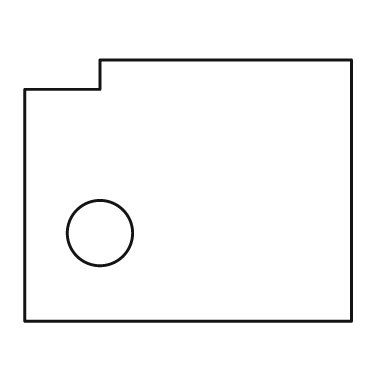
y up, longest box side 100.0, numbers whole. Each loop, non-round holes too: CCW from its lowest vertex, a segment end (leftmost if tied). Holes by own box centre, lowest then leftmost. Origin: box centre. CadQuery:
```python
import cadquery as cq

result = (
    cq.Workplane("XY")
    .moveTo(-50.0, -40.0)
    .lineTo(50.0, -40.0)
    .lineTo(50.0, 40.0)
    .lineTo(-27.0, 40.0)
    .lineTo(-27.0, 31.0)
    .lineTo(-50.0, 31.0)
    .close()
    .moveTo(-27.0, -13.0)
    .circle(10.0)
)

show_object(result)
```